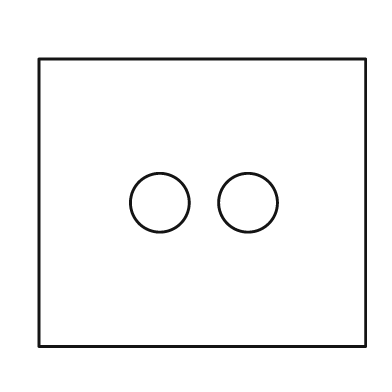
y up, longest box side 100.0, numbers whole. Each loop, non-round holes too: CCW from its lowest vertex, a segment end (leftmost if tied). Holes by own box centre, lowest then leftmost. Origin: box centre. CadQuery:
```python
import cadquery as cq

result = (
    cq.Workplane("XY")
    .moveTo(-50.0, -44.0)
    .lineTo(50.0, -44.0)
    .lineTo(50.0, 44.0)
    .lineTo(-50.0, 44.0)
    .close()
    .moveTo(-13.0, 0.0)
    .circle(9.0)
    .moveTo(14.0, 0.0)
    .circle(9.0)
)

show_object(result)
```